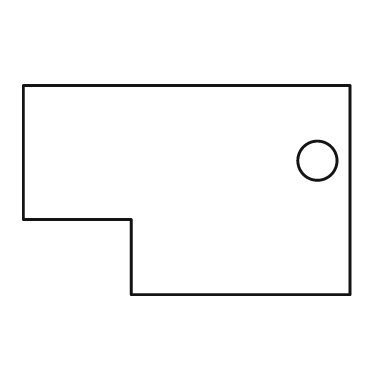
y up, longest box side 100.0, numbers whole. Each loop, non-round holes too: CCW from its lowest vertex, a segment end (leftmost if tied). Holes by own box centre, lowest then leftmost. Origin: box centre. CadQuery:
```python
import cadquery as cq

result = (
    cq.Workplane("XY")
    .moveTo(-17.0, -32.0)
    .lineTo(50.0, -32.0)
    .lineTo(50.0, 32.0)
    .lineTo(-50.0, 32.0)
    .lineTo(-50.0, -9.0)
    .lineTo(-17.0, -9.0)
    .close()
    .moveTo(40.0, 9.0)
    .circle(6.0)
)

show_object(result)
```